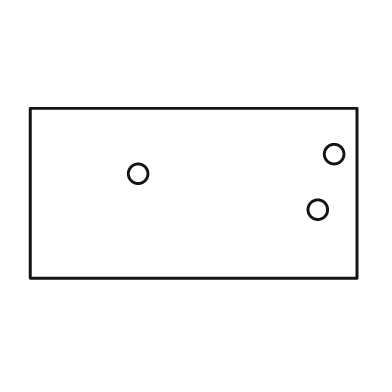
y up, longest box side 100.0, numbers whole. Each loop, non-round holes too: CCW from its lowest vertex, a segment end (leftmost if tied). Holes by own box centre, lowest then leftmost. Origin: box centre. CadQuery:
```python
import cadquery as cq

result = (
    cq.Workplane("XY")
    .moveTo(-50.0, -26.0)
    .lineTo(50.0, -26.0)
    .lineTo(50.0, 26.0)
    .lineTo(-50.0, 26.0)
    .close()
    .moveTo(38.0, -5.0)
    .circle(3.0)
    .moveTo(-17.0, 6.0)
    .circle(3.0)
    .moveTo(43.0, 12.0)
    .circle(3.0)
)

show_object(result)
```